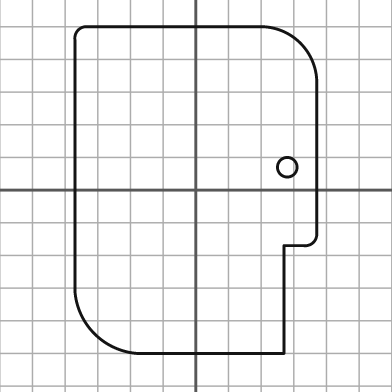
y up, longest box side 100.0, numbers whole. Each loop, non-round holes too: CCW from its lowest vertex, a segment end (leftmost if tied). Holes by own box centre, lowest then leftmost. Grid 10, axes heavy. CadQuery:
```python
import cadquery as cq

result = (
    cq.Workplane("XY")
    .moveTo(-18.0, -50.0)
    .lineTo(27.0, -50.0)
    .lineTo(27.0, -17.0)
    .lineTo(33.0, -17.0)
    .threePointArc((36.0, -16.0), (37.0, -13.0))
    .lineTo(37.0, 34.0)
    .threePointArc((32.0, 45.0), (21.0, 50.0))
    .lineTo(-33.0, 50.0)
    .threePointArc((-36.0, 49.0), (-37.0, 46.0))
    .lineTo(-37.0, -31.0)
    .threePointArc((-31.0, -44.0), (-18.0, -50.0))
    .close()
    .moveTo(28.0, 7.0)
    .circle(3.0)
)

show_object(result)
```